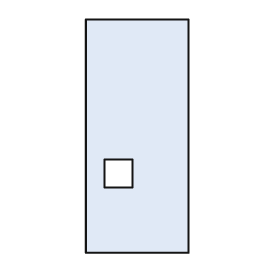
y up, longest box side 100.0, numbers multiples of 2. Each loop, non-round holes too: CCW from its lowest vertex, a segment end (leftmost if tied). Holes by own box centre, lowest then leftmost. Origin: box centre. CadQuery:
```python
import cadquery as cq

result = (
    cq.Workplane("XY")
    .moveTo(-22.0, -50.0)
    .lineTo(22.0, -50.0)
    .lineTo(22.0, 50.0)
    .lineTo(-22.0, 50.0)
    .close()
    .moveTo(-14.0, -22.0)
    .lineTo(-2.0, -22.0)
    .lineTo(-2.0, -10.0)
    .lineTo(-14.0, -10.0)
    .close()
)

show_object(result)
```